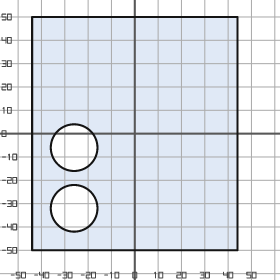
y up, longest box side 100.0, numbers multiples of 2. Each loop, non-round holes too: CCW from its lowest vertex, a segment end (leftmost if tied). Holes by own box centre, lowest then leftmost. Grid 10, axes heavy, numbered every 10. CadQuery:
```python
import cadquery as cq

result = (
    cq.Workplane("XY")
    .moveTo(-44.0, -50.0)
    .lineTo(44.0, -50.0)
    .lineTo(44.0, 50.0)
    .lineTo(-44.0, 50.0)
    .close()
    .moveTo(-26.0, -32.0)
    .circle(10.0)
    .moveTo(-26.0, -6.0)
    .circle(10.0)
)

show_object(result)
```